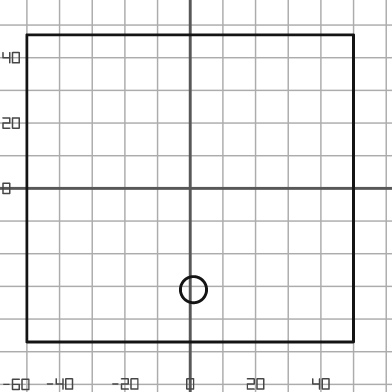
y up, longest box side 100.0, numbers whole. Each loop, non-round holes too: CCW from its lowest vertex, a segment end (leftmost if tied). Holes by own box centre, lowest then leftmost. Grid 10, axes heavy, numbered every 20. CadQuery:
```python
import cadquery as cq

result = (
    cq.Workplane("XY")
    .moveTo(-50.0, -47.0)
    .lineTo(50.0, -47.0)
    .lineTo(50.0, 47.0)
    .lineTo(-50.0, 47.0)
    .close()
    .moveTo(1.0, -31.0)
    .circle(4.0)
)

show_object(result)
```